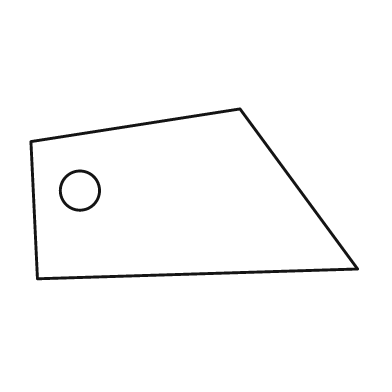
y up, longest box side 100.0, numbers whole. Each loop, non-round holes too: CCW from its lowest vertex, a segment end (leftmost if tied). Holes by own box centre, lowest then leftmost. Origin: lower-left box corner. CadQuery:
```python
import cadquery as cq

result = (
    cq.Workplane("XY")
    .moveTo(2.0, 0.0)
    .lineTo(100.0, 3.0)
    .lineTo(64.0, 52.0)
    .lineTo(0.0, 42.0)
    .close()
    .moveTo(15.0, 27.0)
    .circle(6.0)
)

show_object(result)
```